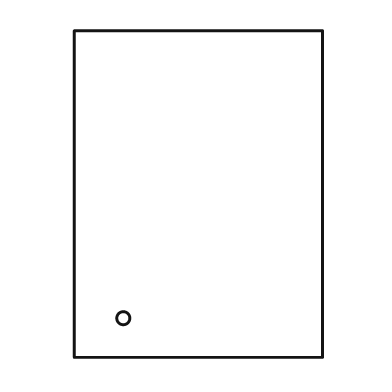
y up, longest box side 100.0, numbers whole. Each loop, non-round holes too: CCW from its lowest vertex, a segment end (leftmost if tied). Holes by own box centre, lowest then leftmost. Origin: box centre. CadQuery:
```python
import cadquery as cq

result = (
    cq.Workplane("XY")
    .moveTo(-38.0, -50.0)
    .lineTo(38.0, -50.0)
    .lineTo(38.0, 50.0)
    .lineTo(-38.0, 50.0)
    .close()
    .moveTo(-23.0, -38.0)
    .circle(2.0)
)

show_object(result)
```